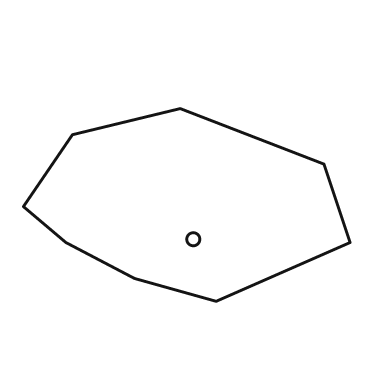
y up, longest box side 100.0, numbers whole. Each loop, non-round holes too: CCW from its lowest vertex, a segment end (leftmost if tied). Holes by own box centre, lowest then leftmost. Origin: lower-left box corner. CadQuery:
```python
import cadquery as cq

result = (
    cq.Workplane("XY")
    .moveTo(59.0, 0.0)
    .lineTo(100.0, 18.0)
    .lineTo(92.0, 42.0)
    .lineTo(48.0, 59.0)
    .lineTo(15.0, 51.0)
    .lineTo(0.0, 29.0)
    .lineTo(13.0, 18.0)
    .lineTo(34.0, 7.0)
    .close()
    .moveTo(52.0, 19.0)
    .circle(2.0)
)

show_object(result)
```